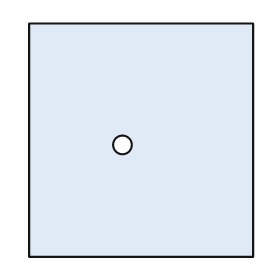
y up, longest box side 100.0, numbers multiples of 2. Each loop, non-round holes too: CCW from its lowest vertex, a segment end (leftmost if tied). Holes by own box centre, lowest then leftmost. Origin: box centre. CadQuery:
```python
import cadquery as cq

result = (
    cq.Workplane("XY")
    .moveTo(-48.0, -50.0)
    .lineTo(48.0, -50.0)
    .lineTo(48.0, 50.0)
    .lineTo(-48.0, 50.0)
    .close()
    .moveTo(-8.0, -2.0)
    .circle(4.0)
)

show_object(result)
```